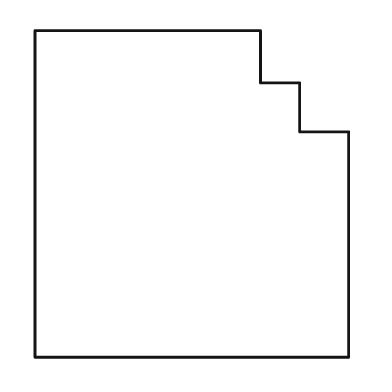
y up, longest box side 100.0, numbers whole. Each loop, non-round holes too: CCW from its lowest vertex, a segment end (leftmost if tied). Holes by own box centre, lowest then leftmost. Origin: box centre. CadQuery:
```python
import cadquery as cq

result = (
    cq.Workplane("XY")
    .moveTo(-48.0, -50.0)
    .lineTo(48.0, -50.0)
    .lineTo(48.0, 19.0)
    .lineTo(33.0, 19.0)
    .lineTo(33.0, 34.0)
    .lineTo(21.0, 34.0)
    .lineTo(21.0, 50.0)
    .lineTo(-48.0, 50.0)
    .close()
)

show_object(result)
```